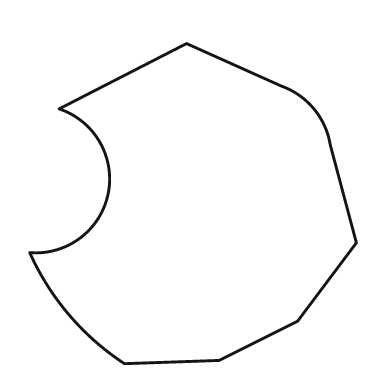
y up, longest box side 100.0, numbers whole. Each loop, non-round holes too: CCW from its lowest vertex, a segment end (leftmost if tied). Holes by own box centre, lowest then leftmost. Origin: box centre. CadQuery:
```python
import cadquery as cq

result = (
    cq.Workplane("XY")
    .moveTo(-21.0, -49.0)
    .lineTo(8.0, -48.0)
    .lineTo(32.0, -36.0)
    .lineTo(50.0, -12.0)
    .lineTo(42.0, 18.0)
    .threePointArc((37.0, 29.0), (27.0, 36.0))
    .lineTo(-2.0, 49.0)
    .lineTo(-41.0, 29.0)
    .threePointArc((-26.0, 3.0), (-50.0, -15.0))
    .threePointArc((-38.0, -34.0), (-21.0, -49.0))
    .close()
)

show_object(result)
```